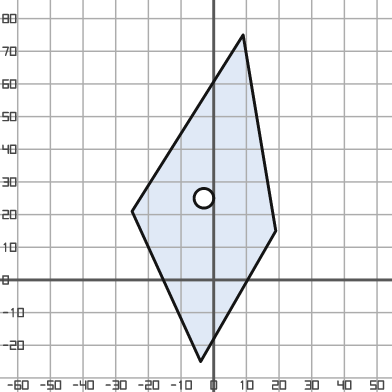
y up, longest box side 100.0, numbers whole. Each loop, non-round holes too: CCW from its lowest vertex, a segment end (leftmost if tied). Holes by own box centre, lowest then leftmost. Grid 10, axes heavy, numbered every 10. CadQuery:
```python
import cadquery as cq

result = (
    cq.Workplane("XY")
    .moveTo(-4.0, -25.0)
    .lineTo(19.0, 15.0)
    .lineTo(9.0, 75.0)
    .lineTo(-25.0, 21.0)
    .close()
    .moveTo(-3.0, 25.0)
    .circle(3.0)
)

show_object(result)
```